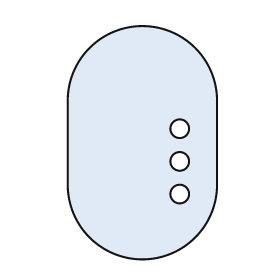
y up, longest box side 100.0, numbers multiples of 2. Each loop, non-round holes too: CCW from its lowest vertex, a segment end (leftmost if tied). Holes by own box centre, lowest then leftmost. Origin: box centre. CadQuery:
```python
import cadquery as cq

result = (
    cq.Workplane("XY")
    .moveTo(-32.0, -18.0)
    .threePointArc((0.0, -50.0), (32.0, -18.0))
    .lineTo(32.0, 18.0)
    .threePointArc((0.0, 50.0), (-32.0, 18.0))
    .close()
    .moveTo(16.0, -22.0)
    .circle(4.0)
    .moveTo(16.0, -8.0)
    .circle(4.0)
    .moveTo(16.0, 6.0)
    .circle(4.0)
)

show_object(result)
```